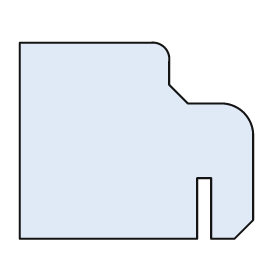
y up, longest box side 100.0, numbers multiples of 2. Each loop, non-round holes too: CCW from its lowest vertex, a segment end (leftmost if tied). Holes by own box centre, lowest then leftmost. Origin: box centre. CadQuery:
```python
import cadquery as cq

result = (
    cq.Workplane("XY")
    .moveTo(-50.0, -42.0)
    .lineTo(26.0, -42.0)
    .lineTo(26.0, -16.0)
    .lineTo(32.0, -16.0)
    .lineTo(32.0, -42.0)
    .lineTo(42.0, -42.0)
    .lineTo(50.0, -34.0)
    .lineTo(50.0, 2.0)
    .threePointArc((46.0, 12.0), (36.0, 16.0))
    .lineTo(22.0, 16.0)
    .lineTo(14.0, 24.0)
    .lineTo(14.0, 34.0)
    .threePointArc((12.0, 40.0), (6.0, 42.0))
    .lineTo(-50.0, 42.0)
    .close()
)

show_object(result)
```